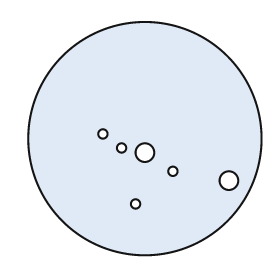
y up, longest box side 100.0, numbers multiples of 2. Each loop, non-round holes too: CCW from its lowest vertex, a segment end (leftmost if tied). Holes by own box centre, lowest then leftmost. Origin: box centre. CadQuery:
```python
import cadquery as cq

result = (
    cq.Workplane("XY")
    .moveTo(0.0, 0.0)
    .circle(50.0)
    .moveTo(-4.0, -28.0)
    .circle(2.0)
    .moveTo(36.0, -18.0)
    .circle(4.0)
    .moveTo(12.0, -14.0)
    .circle(2.0)
    .moveTo(0.0, -6.0)
    .circle(4.0)
    .moveTo(-10.0, -4.0)
    .circle(2.0)
    .moveTo(-18.0, 2.0)
    .circle(2.0)
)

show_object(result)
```